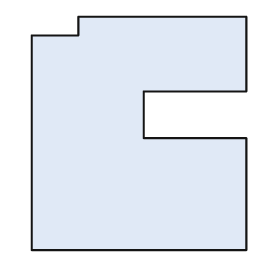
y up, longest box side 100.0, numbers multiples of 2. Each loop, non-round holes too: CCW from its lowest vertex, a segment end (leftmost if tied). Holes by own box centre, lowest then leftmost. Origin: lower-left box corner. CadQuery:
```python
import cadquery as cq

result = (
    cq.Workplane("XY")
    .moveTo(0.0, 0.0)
    .lineTo(92.0, 0.0)
    .lineTo(92.0, 48.0)
    .lineTo(48.0, 48.0)
    .lineTo(48.0, 68.0)
    .lineTo(92.0, 68.0)
    .lineTo(92.0, 100.0)
    .lineTo(20.0, 100.0)
    .lineTo(20.0, 92.0)
    .lineTo(0.0, 92.0)
    .close()
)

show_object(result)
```